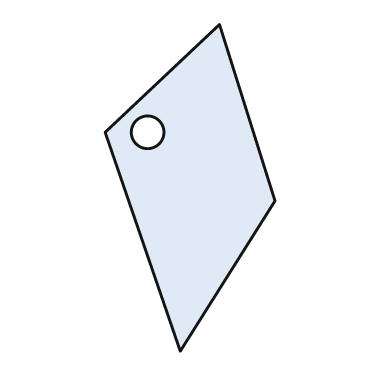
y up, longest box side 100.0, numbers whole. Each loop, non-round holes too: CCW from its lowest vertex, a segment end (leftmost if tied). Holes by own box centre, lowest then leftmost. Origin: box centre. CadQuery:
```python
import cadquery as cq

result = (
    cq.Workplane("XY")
    .moveTo(-3.0, -50.0)
    .lineTo(26.0, -4.0)
    .lineTo(9.0, 50.0)
    .lineTo(-26.0, 17.0)
    .close()
    .moveTo(-13.0, 17.0)
    .circle(5.0)
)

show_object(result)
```